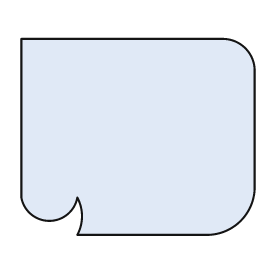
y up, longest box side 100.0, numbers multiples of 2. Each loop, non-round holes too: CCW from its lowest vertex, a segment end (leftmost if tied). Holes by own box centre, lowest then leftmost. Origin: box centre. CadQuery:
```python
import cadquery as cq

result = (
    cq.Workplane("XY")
    .moveTo(-26.0, -42.0)
    .lineTo(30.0, -42.0)
    .threePointArc((44.0, -36.0), (50.0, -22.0))
    .lineTo(50.0, 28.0)
    .threePointArc((46.0, 38.0), (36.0, 42.0))
    .lineTo(-50.0, 42.0)
    .lineTo(-50.0, -26.0)
    .threePointArc((-38.0, -36.0), (-26.0, -26.0))
    .threePointArc((-24.0, -34.0), (-26.0, -42.0))
    .close()
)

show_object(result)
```